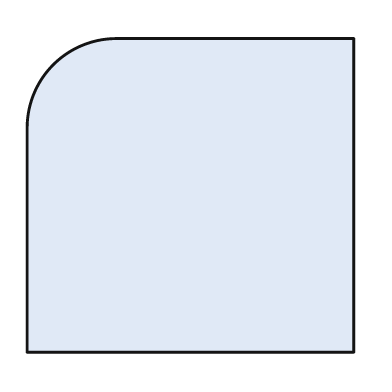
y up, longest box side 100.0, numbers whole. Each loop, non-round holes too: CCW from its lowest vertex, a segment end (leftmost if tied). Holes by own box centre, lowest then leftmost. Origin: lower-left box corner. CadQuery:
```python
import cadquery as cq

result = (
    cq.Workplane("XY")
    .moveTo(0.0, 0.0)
    .lineTo(100.0, 0.0)
    .lineTo(100.0, 96.0)
    .lineTo(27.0, 96.0)
    .threePointArc((8.0, 88.0), (0.0, 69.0))
    .close()
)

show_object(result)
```